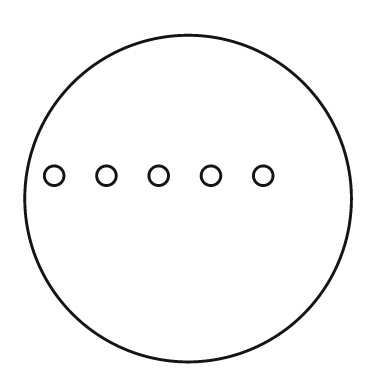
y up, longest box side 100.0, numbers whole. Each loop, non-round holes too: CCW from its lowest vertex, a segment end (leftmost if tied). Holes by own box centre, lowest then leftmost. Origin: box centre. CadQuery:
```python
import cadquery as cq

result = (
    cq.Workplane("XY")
    .moveTo(0.0, 0.0)
    .circle(50.0)
    .moveTo(-41.0, 7.0)
    .circle(3.0)
    .moveTo(-25.0, 7.0)
    .circle(3.0)
    .moveTo(-9.0, 7.0)
    .circle(3.0)
    .moveTo(7.0, 7.0)
    .circle(3.0)
    .moveTo(23.0, 7.0)
    .circle(3.0)
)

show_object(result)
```